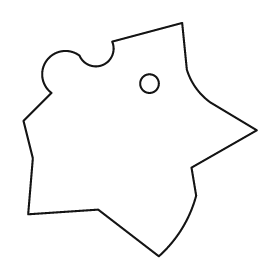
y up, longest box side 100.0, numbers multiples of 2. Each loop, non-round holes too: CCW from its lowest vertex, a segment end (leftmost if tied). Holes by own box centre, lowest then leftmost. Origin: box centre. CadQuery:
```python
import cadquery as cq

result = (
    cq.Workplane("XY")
    .moveTo(8.0, -50.0)
    .threePointArc((18.0, -38.0), (24.0, -24.0))
    .lineTo(22.0, -12.0)
    .lineTo(50.0, 4.0)
    .lineTo(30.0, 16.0)
    .threePointArc((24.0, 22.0), (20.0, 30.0))
    .lineTo(18.0, 50.0)
    .lineTo(-12.0, 42.0)
    .threePointArc((-16.0, 32.0), (-26.0, 36.0))
    .threePointArc((-40.0, 34.0), (-38.0, 20.0))
    .lineTo(-50.0, 8.0)
    .lineTo(-46.0, -8.0)
    .lineTo(-48.0, -32.0)
    .lineTo(-18.0, -30.0)
    .close()
    .moveTo(4.0, 24.0)
    .circle(4.0)
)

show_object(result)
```